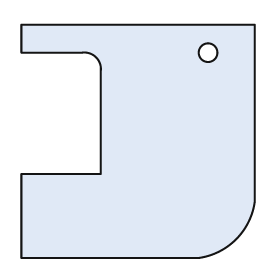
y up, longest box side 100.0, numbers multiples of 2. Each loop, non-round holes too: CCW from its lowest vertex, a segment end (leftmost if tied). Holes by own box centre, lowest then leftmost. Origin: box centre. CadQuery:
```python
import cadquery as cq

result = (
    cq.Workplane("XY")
    .moveTo(-50.0, -50.0)
    .lineTo(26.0, -50.0)
    .threePointArc((42.0, -42.0), (50.0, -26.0))
    .lineTo(50.0, 50.0)
    .lineTo(-50.0, 50.0)
    .lineTo(-50.0, 38.0)
    .lineTo(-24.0, 38.0)
    .threePointArc((-18.0, 36.0), (-16.0, 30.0))
    .lineTo(-16.0, -14.0)
    .lineTo(-50.0, -14.0)
    .close()
    .moveTo(30.0, 38.0)
    .circle(4.0)
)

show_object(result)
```